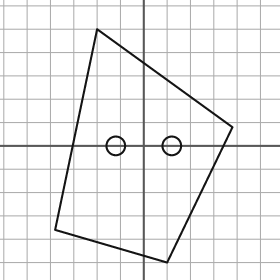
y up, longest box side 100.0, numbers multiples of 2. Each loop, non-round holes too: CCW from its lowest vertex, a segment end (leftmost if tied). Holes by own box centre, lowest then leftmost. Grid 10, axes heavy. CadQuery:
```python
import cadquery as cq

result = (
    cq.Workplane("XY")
    .moveTo(10.0, -50.0)
    .lineTo(38.0, 8.0)
    .lineTo(-20.0, 50.0)
    .lineTo(-38.0, -36.0)
    .close()
    .moveTo(-12.0, 0.0)
    .circle(4.0)
    .moveTo(12.0, 0.0)
    .circle(4.0)
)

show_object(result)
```